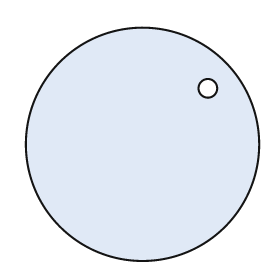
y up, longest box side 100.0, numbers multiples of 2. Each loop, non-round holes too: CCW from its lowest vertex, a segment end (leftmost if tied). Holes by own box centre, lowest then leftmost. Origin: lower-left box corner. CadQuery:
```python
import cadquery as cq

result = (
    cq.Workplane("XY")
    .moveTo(50.0, 50.0)
    .circle(50.0)
    .moveTo(78.0, 74.0)
    .circle(4.0)
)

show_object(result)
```